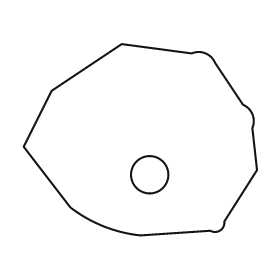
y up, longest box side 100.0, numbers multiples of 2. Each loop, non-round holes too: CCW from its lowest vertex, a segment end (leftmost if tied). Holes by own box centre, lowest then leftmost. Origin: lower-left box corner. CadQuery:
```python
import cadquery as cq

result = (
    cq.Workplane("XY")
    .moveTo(50.0, 0.0)
    .lineTo(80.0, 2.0)
    .threePointArc((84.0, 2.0), (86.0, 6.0))
    .lineTo(100.0, 28.0)
    .lineTo(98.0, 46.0)
    .threePointArc((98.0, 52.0), (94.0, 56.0))
    .lineTo(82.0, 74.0)
    .threePointArc((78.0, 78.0), (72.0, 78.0))
    .lineTo(42.0, 82.0)
    .lineTo(12.0, 62.0)
    .lineTo(0.0, 38.0)
    .lineTo(20.0, 12.0)
    .threePointArc((34.0, 4.0), (50.0, 0.0))
    .close()
    .moveTo(54.0, 26.0)
    .circle(8.0)
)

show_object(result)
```